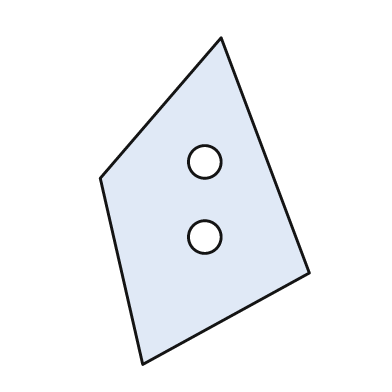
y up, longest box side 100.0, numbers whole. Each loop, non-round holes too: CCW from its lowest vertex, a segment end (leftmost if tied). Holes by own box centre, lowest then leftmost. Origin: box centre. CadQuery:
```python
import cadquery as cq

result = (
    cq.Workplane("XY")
    .moveTo(-19.0, -50.0)
    .lineTo(32.0, -22.0)
    .lineTo(5.0, 50.0)
    .lineTo(-32.0, 7.0)
    .close()
    .moveTo(0.0, -11.0)
    .circle(5.0)
    .moveTo(0.0, 12.0)
    .circle(5.0)
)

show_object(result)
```